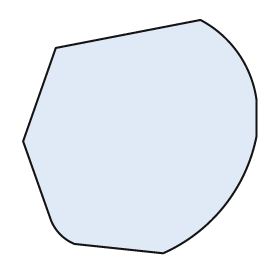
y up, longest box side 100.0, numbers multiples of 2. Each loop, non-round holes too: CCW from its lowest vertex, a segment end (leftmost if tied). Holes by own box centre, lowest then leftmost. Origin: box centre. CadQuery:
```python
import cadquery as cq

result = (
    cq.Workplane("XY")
    .moveTo(10.0, -50.0)
    .threePointArc((36.0, -30.0), (50.0, 0.0))
    .lineTo(50.0, 16.0)
    .threePointArc((42.0, 36.0), (26.0, 50.0))
    .lineTo(-36.0, 38.0)
    .lineTo(-50.0, -2.0)
    .lineTo(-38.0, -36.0)
    .threePointArc((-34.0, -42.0), (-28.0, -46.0))
    .close()
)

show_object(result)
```